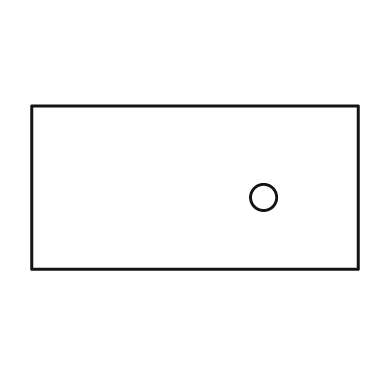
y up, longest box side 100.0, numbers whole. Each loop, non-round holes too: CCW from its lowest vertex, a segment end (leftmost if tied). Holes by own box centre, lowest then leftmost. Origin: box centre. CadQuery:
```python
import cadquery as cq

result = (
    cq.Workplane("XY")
    .moveTo(-50.0, -25.0)
    .lineTo(50.0, -25.0)
    .lineTo(50.0, 25.0)
    .lineTo(-50.0, 25.0)
    .close()
    .moveTo(21.0, -3.0)
    .circle(4.0)
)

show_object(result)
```